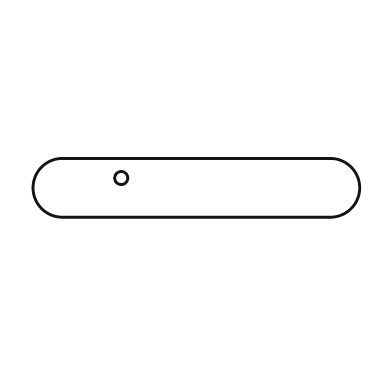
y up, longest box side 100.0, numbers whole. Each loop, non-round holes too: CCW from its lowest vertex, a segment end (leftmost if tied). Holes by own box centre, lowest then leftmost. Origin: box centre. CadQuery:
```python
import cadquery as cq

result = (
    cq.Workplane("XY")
    .moveTo(-41.0, -9.0)
    .lineTo(41.0, -9.0)
    .threePointArc((50.0, 0.0), (41.0, 9.0))
    .lineTo(-41.0, 9.0)
    .threePointArc((-50.0, 0.0), (-41.0, -9.0))
    .close()
    .moveTo(-23.0, 3.0)
    .circle(2.0)
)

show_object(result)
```